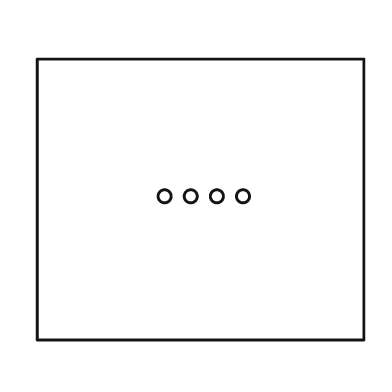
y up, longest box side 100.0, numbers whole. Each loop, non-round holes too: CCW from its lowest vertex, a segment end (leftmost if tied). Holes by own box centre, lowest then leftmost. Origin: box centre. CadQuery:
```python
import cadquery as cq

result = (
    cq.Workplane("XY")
    .moveTo(-50.0, -43.0)
    .lineTo(50.0, -43.0)
    .lineTo(50.0, 43.0)
    .lineTo(-50.0, 43.0)
    .close()
    .moveTo(-11.0, 1.0)
    .circle(2.0)
    .moveTo(-3.0, 1.0)
    .circle(2.0)
    .moveTo(5.0, 1.0)
    .circle(2.0)
    .moveTo(13.0, 1.0)
    .circle(2.0)
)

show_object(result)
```